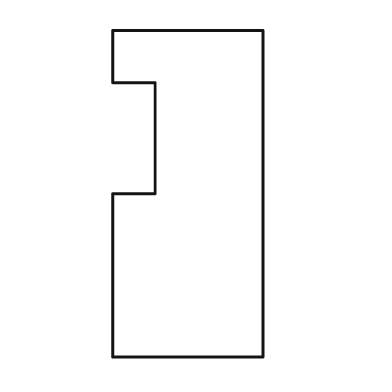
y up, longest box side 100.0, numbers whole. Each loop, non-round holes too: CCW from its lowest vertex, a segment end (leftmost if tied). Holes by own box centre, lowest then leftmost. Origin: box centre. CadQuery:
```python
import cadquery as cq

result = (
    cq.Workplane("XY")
    .moveTo(-23.0, -50.0)
    .lineTo(23.0, -50.0)
    .lineTo(23.0, 50.0)
    .lineTo(-23.0, 50.0)
    .lineTo(-23.0, 34.0)
    .lineTo(-10.0, 34.0)
    .lineTo(-10.0, 0.0)
    .lineTo(-23.0, 0.0)
    .close()
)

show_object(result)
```